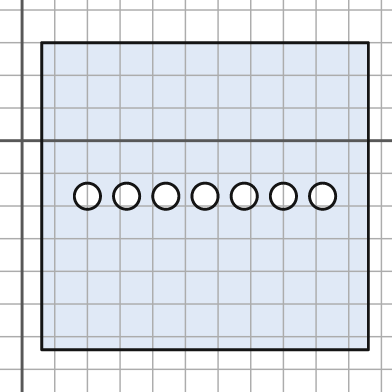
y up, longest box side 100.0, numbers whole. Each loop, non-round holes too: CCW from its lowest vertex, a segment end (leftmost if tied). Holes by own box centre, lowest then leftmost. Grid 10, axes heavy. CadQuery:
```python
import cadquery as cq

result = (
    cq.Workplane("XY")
    .moveTo(6.0, -64.0)
    .lineTo(106.0, -64.0)
    .lineTo(106.0, 30.0)
    .lineTo(6.0, 30.0)
    .close()
    .moveTo(20.0, -17.0)
    .circle(4.0)
    .moveTo(32.0, -17.0)
    .circle(4.0)
    .moveTo(44.0, -17.0)
    .circle(4.0)
    .moveTo(56.0, -17.0)
    .circle(4.0)
    .moveTo(68.0, -17.0)
    .circle(4.0)
    .moveTo(80.0, -17.0)
    .circle(4.0)
    .moveTo(92.0, -17.0)
    .circle(4.0)
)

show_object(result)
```